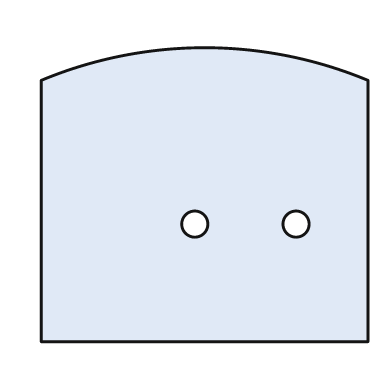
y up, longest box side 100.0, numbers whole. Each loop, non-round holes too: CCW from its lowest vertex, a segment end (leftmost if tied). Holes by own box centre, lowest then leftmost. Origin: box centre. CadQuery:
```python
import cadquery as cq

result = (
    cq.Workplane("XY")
    .moveTo(-50.0, -45.0)
    .lineTo(50.0, -45.0)
    .lineTo(50.0, 35.0)
    .threePointArc((0.0, 45.0), (-50.0, 35.0))
    .close()
    .moveTo(-3.0, -9.0)
    .circle(4.0)
    .moveTo(28.0, -9.0)
    .circle(4.0)
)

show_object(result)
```